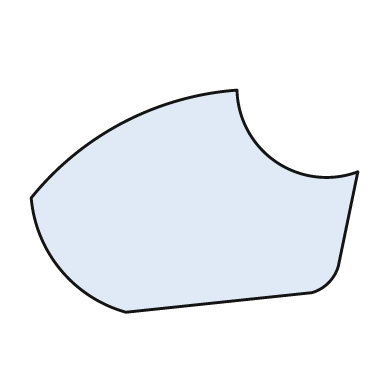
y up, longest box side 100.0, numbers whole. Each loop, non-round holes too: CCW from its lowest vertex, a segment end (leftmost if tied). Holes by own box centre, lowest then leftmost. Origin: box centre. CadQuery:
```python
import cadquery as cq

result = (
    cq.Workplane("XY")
    .moveTo(-21.0, -34.0)
    .lineTo(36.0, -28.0)
    .threePointArc((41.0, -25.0), (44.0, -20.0))
    .lineTo(50.0, 9.0)
    .threePointArc((25.0, 12.0), (13.0, 34.0))
    .threePointArc((-22.0, 24.0), (-50.0, 1.0))
    .threePointArc((-41.0, -21.0), (-21.0, -34.0))
    .close()
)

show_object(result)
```